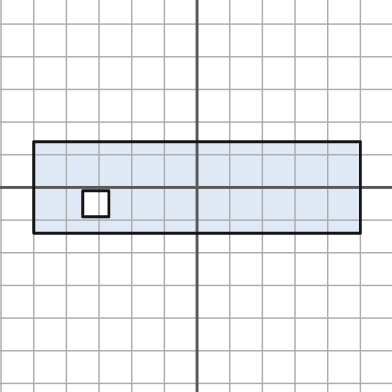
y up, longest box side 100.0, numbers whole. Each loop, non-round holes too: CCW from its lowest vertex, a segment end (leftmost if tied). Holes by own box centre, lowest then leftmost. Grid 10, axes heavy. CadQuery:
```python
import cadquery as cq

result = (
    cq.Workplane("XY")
    .moveTo(-50.0, -14.0)
    .lineTo(50.0, -14.0)
    .lineTo(50.0, 14.0)
    .lineTo(-50.0, 14.0)
    .close()
    .moveTo(-35.0, -9.0)
    .lineTo(-27.0, -9.0)
    .lineTo(-27.0, -1.0)
    .lineTo(-35.0, -1.0)
    .close()
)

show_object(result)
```